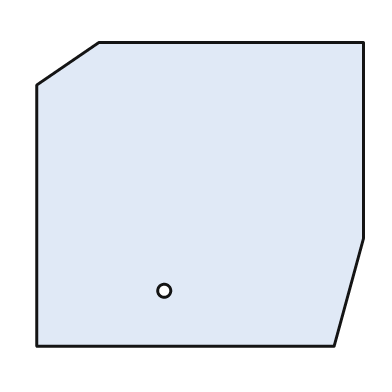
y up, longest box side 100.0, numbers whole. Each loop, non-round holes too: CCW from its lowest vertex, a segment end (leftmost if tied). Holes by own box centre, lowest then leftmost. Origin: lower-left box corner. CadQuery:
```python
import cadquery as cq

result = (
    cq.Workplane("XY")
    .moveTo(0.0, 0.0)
    .lineTo(91.0, 0.0)
    .lineTo(100.0, 33.0)
    .lineTo(100.0, 93.0)
    .lineTo(19.0, 93.0)
    .lineTo(0.0, 80.0)
    .close()
    .moveTo(39.0, 17.0)
    .circle(2.0)
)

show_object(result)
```